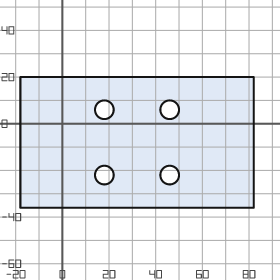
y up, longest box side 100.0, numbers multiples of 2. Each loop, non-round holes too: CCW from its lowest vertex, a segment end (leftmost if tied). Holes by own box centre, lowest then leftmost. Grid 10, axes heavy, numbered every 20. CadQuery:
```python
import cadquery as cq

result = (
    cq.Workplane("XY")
    .moveTo(-18.0, -36.0)
    .lineTo(82.0, -36.0)
    .lineTo(82.0, 20.0)
    .lineTo(-18.0, 20.0)
    .close()
    .moveTo(18.0, -22.0)
    .circle(4.0)
    .moveTo(46.0, -22.0)
    .circle(4.0)
    .moveTo(18.0, 6.0)
    .circle(4.0)
    .moveTo(46.0, 6.0)
    .circle(4.0)
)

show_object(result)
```